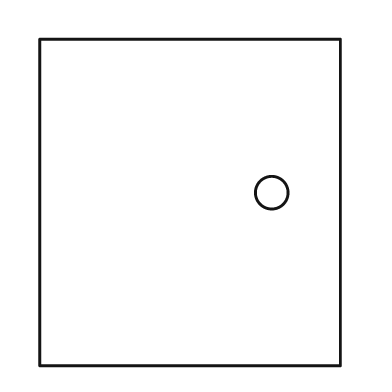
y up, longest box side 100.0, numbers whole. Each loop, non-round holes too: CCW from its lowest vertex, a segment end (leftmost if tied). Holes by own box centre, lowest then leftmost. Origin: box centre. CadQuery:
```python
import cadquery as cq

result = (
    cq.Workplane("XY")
    .moveTo(-46.0, -50.0)
    .lineTo(46.0, -50.0)
    .lineTo(46.0, 50.0)
    .lineTo(-46.0, 50.0)
    .close()
    .moveTo(25.0, 3.0)
    .circle(5.0)
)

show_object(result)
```